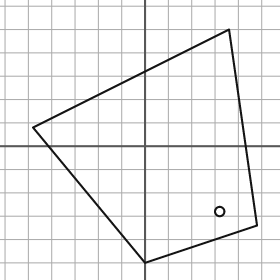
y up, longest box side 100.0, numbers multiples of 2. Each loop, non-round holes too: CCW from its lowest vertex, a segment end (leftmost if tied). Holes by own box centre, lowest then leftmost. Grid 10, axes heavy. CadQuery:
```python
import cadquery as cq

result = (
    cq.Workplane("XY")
    .moveTo(0.0, -50.0)
    .lineTo(48.0, -34.0)
    .lineTo(36.0, 50.0)
    .lineTo(-48.0, 8.0)
    .close()
    .moveTo(32.0, -28.0)
    .circle(2.0)
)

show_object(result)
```